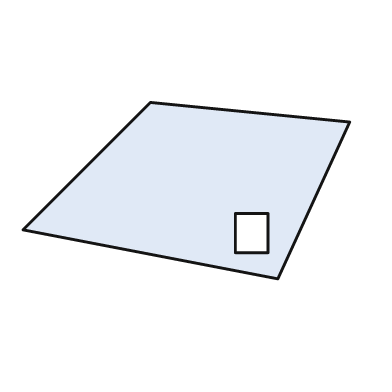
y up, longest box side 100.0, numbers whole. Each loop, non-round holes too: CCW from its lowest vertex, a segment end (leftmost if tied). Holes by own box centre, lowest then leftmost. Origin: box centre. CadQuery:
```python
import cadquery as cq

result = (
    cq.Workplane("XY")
    .moveTo(28.0, -27.0)
    .lineTo(50.0, 21.0)
    .lineTo(-11.0, 27.0)
    .lineTo(-50.0, -12.0)
    .close()
    .moveTo(15.0, -19.0)
    .lineTo(25.0, -19.0)
    .lineTo(25.0, -7.0)
    .lineTo(15.0, -7.0)
    .close()
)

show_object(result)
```